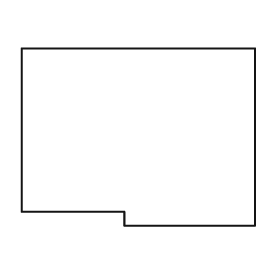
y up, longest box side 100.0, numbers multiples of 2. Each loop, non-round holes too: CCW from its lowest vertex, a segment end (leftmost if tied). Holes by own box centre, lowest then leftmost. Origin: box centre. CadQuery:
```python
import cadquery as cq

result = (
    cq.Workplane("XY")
    .moveTo(-6.0, -38.0)
    .lineTo(50.0, -38.0)
    .lineTo(50.0, 38.0)
    .lineTo(-50.0, 38.0)
    .lineTo(-50.0, -32.0)
    .lineTo(-6.0, -32.0)
    .close()
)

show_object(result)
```